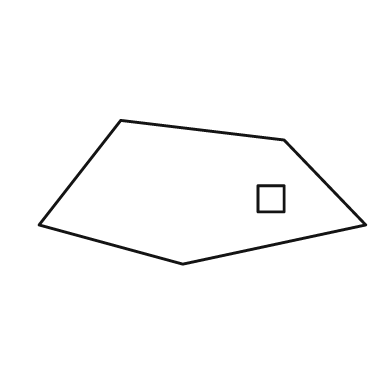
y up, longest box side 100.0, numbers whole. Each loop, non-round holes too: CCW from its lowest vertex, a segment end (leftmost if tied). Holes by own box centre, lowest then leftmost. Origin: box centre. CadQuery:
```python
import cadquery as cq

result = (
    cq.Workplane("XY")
    .moveTo(-6.0, -22.0)
    .lineTo(50.0, -10.0)
    .lineTo(25.0, 16.0)
    .lineTo(-25.0, 22.0)
    .lineTo(-50.0, -10.0)
    .close()
    .moveTo(17.0, -6.0)
    .lineTo(25.0, -6.0)
    .lineTo(25.0, 2.0)
    .lineTo(17.0, 2.0)
    .close()
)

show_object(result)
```